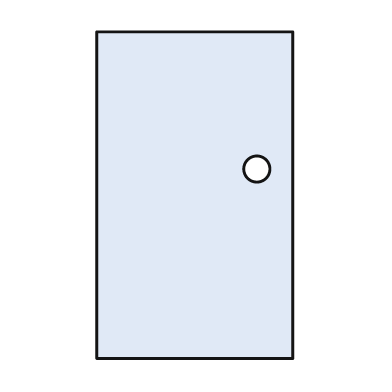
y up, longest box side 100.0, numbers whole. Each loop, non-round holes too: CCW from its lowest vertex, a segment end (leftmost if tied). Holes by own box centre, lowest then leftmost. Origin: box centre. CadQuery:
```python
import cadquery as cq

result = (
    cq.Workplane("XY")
    .moveTo(-30.0, -50.0)
    .lineTo(30.0, -50.0)
    .lineTo(30.0, 50.0)
    .lineTo(-30.0, 50.0)
    .close()
    .moveTo(19.0, 8.0)
    .circle(4.0)
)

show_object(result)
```